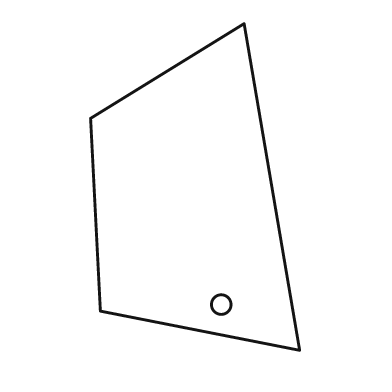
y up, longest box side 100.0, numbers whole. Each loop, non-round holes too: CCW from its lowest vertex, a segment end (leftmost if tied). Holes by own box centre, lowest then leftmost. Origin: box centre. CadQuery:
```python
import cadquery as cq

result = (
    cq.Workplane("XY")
    .moveTo(32.0, -50.0)
    .lineTo(15.0, 50.0)
    .lineTo(-32.0, 21.0)
    .lineTo(-29.0, -38.0)
    .close()
    .moveTo(8.0, -36.0)
    .circle(3.0)
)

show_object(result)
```